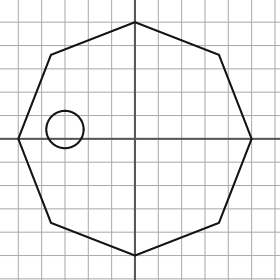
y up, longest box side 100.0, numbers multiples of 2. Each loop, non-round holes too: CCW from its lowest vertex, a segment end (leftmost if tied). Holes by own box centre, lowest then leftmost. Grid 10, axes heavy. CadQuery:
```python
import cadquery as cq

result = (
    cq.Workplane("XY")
    .moveTo(0.0, -50.0)
    .lineTo(36.0, -36.0)
    .lineTo(50.0, 0.0)
    .lineTo(36.0, 36.0)
    .lineTo(0.0, 50.0)
    .lineTo(-36.0, 36.0)
    .lineTo(-50.0, 0.0)
    .lineTo(-36.0, -36.0)
    .close()
    .moveTo(-30.0, 4.0)
    .circle(8.0)
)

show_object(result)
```